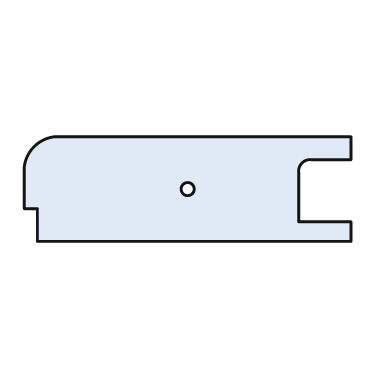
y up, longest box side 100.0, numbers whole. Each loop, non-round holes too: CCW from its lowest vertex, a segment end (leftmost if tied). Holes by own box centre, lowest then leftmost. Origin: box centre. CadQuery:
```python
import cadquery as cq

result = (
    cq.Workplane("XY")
    .moveTo(-46.0, -16.0)
    .lineTo(50.0, -16.0)
    .lineTo(50.0, -10.0)
    .lineTo(34.0, -10.0)
    .lineTo(34.0, 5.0)
    .threePointArc((35.0, 8.0), (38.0, 9.0))
    .lineTo(50.0, 9.0)
    .lineTo(50.0, 16.0)
    .lineTo(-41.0, 16.0)
    .threePointArc((-47.0, 13.0), (-50.0, 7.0))
    .lineTo(-50.0, -6.0)
    .lineTo(-46.0, -6.0)
    .close()
    .moveTo(0.0, 0.0)
    .circle(2.0)
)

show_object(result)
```